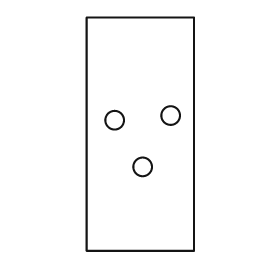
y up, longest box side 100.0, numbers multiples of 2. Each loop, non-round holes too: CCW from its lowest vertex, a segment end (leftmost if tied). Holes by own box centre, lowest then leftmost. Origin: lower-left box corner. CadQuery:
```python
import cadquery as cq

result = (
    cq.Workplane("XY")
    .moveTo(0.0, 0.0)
    .lineTo(46.0, 0.0)
    .lineTo(46.0, 100.0)
    .lineTo(0.0, 100.0)
    .close()
    .moveTo(24.0, 36.0)
    .circle(4.0)
    .moveTo(12.0, 56.0)
    .circle(4.0)
    .moveTo(36.0, 58.0)
    .circle(4.0)
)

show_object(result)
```